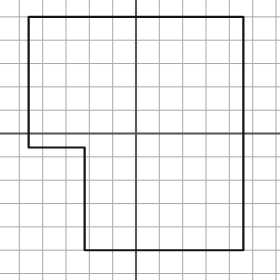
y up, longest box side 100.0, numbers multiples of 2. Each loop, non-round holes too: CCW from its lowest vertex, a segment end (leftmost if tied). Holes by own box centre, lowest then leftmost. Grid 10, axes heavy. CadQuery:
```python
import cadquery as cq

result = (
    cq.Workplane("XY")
    .moveTo(-22.0, -50.0)
    .lineTo(46.0, -50.0)
    .lineTo(46.0, 50.0)
    .lineTo(-46.0, 50.0)
    .lineTo(-46.0, -6.0)
    .lineTo(-22.0, -6.0)
    .close()
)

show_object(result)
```